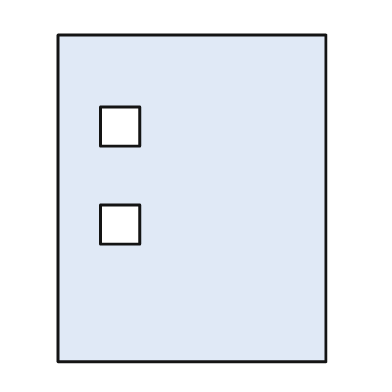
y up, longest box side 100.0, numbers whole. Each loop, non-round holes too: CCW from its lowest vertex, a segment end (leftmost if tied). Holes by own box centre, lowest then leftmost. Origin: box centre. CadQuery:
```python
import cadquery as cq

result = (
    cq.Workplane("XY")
    .moveTo(-41.0, -50.0)
    .lineTo(41.0, -50.0)
    .lineTo(41.0, 50.0)
    .lineTo(-41.0, 50.0)
    .close()
    .moveTo(-28.0, -14.0)
    .lineTo(-16.0, -14.0)
    .lineTo(-16.0, -2.0)
    .lineTo(-28.0, -2.0)
    .close()
    .moveTo(-28.0, 16.0)
    .lineTo(-16.0, 16.0)
    .lineTo(-16.0, 28.0)
    .lineTo(-28.0, 28.0)
    .close()
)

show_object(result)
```